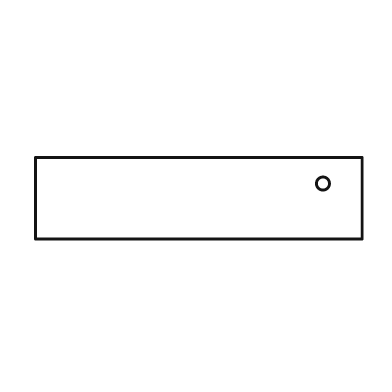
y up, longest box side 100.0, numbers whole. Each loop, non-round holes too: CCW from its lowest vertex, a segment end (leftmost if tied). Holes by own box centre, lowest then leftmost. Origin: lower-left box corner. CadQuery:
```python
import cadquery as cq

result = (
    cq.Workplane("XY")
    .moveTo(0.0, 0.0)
    .lineTo(100.0, 0.0)
    .lineTo(100.0, 25.0)
    .lineTo(0.0, 25.0)
    .close()
    .moveTo(88.0, 17.0)
    .circle(2.0)
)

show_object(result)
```